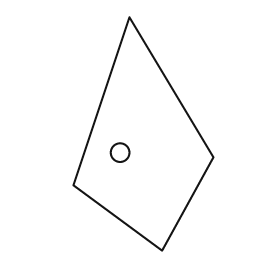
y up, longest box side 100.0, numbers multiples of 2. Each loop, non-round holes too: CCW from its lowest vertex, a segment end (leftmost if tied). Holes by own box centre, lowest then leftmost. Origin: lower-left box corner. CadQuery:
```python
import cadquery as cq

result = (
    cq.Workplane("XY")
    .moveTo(38.0, 0.0)
    .lineTo(60.0, 40.0)
    .lineTo(24.0, 100.0)
    .lineTo(0.0, 28.0)
    .close()
    .moveTo(20.0, 42.0)
    .circle(4.0)
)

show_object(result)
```